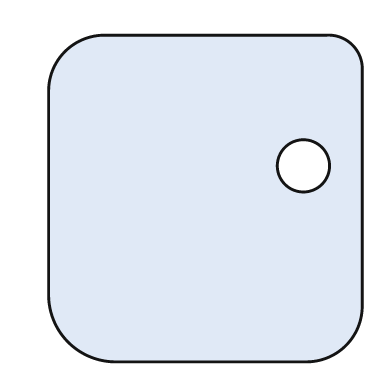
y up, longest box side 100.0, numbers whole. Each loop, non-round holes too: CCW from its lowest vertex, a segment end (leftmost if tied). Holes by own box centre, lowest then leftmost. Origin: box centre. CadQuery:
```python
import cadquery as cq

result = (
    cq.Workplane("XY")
    .moveTo(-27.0, -50.0)
    .lineTo(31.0, -50.0)
    .threePointArc((43.0, -45.0), (48.0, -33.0))
    .lineTo(48.0, 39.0)
    .threePointArc((45.0, 47.0), (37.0, 50.0))
    .lineTo(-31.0, 50.0)
    .threePointArc((-43.0, 45.0), (-48.0, 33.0))
    .lineTo(-48.0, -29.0)
    .threePointArc((-42.0, -44.0), (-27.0, -50.0))
    .close()
    .moveTo(30.0, 10.0)
    .circle(8.0)
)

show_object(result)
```